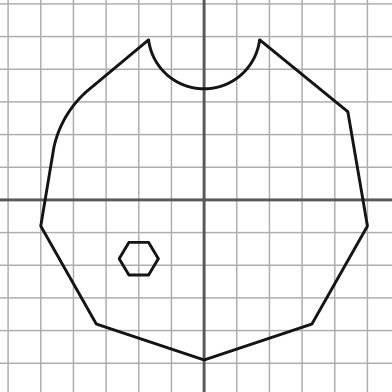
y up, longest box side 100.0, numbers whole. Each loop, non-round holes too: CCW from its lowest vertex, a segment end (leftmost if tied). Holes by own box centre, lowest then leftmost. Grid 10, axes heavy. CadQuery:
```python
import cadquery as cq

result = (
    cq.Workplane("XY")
    .moveTo(0.0, -49.0)
    .lineTo(33.0, -38.0)
    .lineTo(50.0, -8.0)
    .lineTo(44.0, 27.0)
    .lineTo(17.0, 49.0)
    .threePointArc((0.0, 34.0), (-17.0, 49.0))
    .lineTo(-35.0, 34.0)
    .threePointArc((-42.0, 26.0), (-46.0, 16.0))
    .lineTo(-50.0, -8.0)
    .lineTo(-33.0, -38.0)
    .close()
    .moveTo(-23.0, -23.0)
    .lineTo(-17.0, -23.0)
    .lineTo(-14.0, -18.0)
    .lineTo(-17.0, -13.0)
    .lineTo(-23.0, -13.0)
    .lineTo(-26.0, -18.0)
    .close()
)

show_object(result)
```